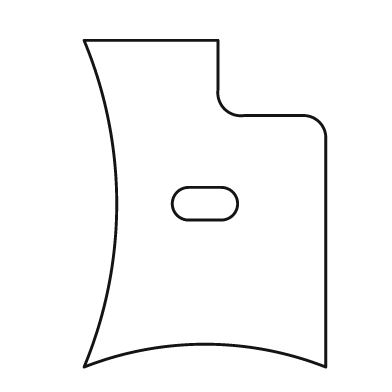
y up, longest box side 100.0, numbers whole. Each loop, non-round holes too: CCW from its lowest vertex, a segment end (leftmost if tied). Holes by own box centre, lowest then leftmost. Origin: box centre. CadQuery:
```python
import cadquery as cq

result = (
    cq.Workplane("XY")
    .moveTo(-37.0, -50.0)
    .threePointArc((0.0, -43.0), (37.0, -50.0))
    .lineTo(37.0, 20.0)
    .threePointArc((35.0, 25.0), (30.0, 27.0))
    .lineTo(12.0, 27.0)
    .threePointArc((6.0, 29.0), (4.0, 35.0))
    .lineTo(4.0, 50.0)
    .lineTo(-37.0, 50.0)
    .threePointArc((-27.0, 0.0), (-37.0, -50.0))
    .close()
    .moveTo(-5.0, -5.0)
    .lineTo(5.0, -5.0)
    .threePointArc((10.0, 0.0), (5.0, 5.0))
    .lineTo(-5.0, 5.0)
    .threePointArc((-10.0, 0.0), (-5.0, -5.0))
    .close()
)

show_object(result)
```